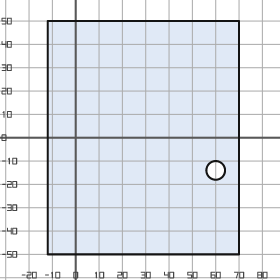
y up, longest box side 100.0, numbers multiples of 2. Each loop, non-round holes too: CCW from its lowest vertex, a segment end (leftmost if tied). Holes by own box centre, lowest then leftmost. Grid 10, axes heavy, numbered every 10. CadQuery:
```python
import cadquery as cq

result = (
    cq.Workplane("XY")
    .moveTo(-12.0, -50.0)
    .lineTo(70.0, -50.0)
    .lineTo(70.0, 50.0)
    .lineTo(-12.0, 50.0)
    .close()
    .moveTo(60.0, -14.0)
    .circle(4.0)
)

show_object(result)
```